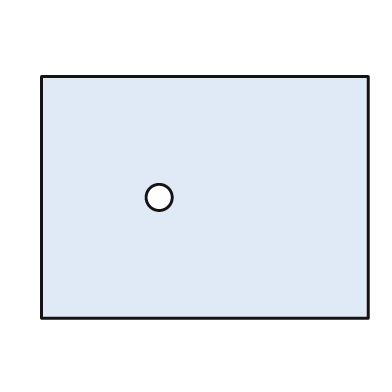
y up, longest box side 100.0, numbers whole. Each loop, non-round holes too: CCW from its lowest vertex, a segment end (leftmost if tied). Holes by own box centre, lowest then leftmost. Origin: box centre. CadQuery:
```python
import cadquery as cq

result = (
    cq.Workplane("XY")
    .moveTo(-50.0, -37.0)
    .lineTo(50.0, -37.0)
    .lineTo(50.0, 37.0)
    .lineTo(-50.0, 37.0)
    .close()
    .moveTo(-14.0, 0.0)
    .circle(4.0)
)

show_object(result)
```